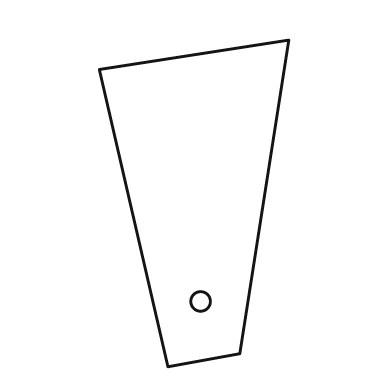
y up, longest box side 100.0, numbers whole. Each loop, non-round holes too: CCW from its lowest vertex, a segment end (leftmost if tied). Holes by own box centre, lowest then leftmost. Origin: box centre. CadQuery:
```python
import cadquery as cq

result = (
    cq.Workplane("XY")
    .moveTo(-8.0, -50.0)
    .lineTo(14.0, -46.0)
    .lineTo(29.0, 50.0)
    .lineTo(-29.0, 41.0)
    .close()
    .moveTo(2.0, -30.0)
    .circle(3.0)
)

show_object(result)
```